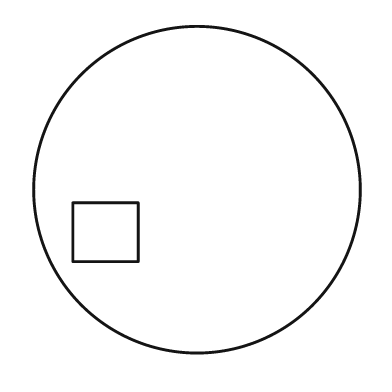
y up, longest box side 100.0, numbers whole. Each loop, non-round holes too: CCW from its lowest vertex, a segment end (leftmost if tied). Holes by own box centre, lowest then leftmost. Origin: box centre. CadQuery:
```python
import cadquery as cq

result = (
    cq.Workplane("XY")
    .moveTo(0.0, 0.0)
    .circle(50.0)
    .moveTo(-38.0, -22.0)
    .lineTo(-18.0, -22.0)
    .lineTo(-18.0, -4.0)
    .lineTo(-38.0, -4.0)
    .close()
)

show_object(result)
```